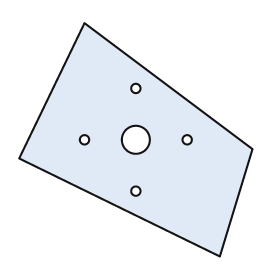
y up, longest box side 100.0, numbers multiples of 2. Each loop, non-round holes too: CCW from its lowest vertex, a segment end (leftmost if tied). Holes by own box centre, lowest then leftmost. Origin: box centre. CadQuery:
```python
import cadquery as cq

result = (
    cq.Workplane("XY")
    .moveTo(36.0, -50.0)
    .lineTo(50.0, -4.0)
    .lineTo(-22.0, 50.0)
    .lineTo(-50.0, -8.0)
    .close()
    .moveTo(0.0, -22.0)
    .circle(2.0)
    .moveTo(-22.0, 0.0)
    .circle(2.0)
    .moveTo(0.0, 0.0)
    .circle(6.0)
    .moveTo(22.0, 0.0)
    .circle(2.0)
    .moveTo(0.0, 22.0)
    .circle(2.0)
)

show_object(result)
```